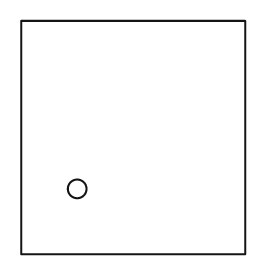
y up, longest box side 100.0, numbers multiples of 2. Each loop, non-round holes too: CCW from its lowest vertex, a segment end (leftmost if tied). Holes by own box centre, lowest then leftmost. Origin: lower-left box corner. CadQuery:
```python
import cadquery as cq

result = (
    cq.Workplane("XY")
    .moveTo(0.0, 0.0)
    .lineTo(96.0, 0.0)
    .lineTo(96.0, 100.0)
    .lineTo(0.0, 100.0)
    .close()
    .moveTo(24.0, 28.0)
    .circle(4.0)
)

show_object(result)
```